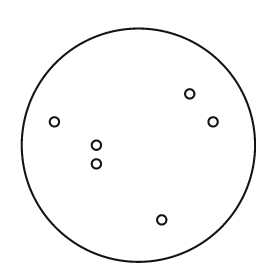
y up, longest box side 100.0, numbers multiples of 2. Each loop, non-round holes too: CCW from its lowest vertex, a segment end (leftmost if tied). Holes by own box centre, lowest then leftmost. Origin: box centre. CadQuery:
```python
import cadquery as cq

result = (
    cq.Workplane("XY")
    .moveTo(0.0, 0.0)
    .circle(50.0)
    .moveTo(10.0, -32.0)
    .circle(2.0)
    .moveTo(-18.0, -8.0)
    .circle(2.0)
    .moveTo(-18.0, 0.0)
    .circle(2.0)
    .moveTo(-36.0, 10.0)
    .circle(2.0)
    .moveTo(32.0, 10.0)
    .circle(2.0)
    .moveTo(22.0, 22.0)
    .circle(2.0)
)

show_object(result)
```